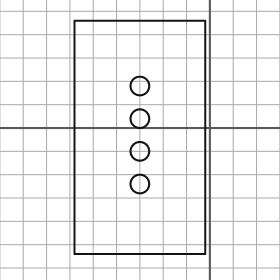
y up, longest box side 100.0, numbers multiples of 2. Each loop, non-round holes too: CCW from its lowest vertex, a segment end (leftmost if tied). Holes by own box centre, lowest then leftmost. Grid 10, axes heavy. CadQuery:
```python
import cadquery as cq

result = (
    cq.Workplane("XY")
    .moveTo(-58.0, -54.0)
    .lineTo(-2.0, -54.0)
    .lineTo(-2.0, 46.0)
    .lineTo(-58.0, 46.0)
    .close()
    .moveTo(-30.0, -24.0)
    .circle(4.0)
    .moveTo(-30.0, -10.0)
    .circle(4.0)
    .moveTo(-30.0, 4.0)
    .circle(4.0)
    .moveTo(-30.0, 18.0)
    .circle(4.0)
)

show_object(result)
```